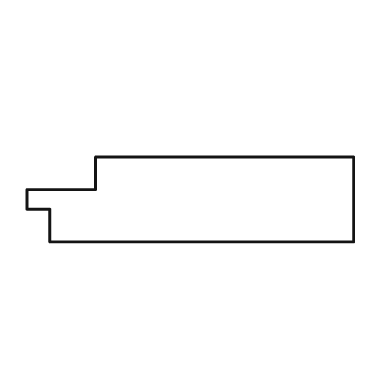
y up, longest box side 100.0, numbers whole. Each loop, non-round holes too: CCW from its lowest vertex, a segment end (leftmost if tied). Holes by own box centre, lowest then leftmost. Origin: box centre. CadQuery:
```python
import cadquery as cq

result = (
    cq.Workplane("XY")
    .moveTo(-43.0, -13.0)
    .lineTo(50.0, -13.0)
    .lineTo(50.0, 13.0)
    .lineTo(-29.0, 13.0)
    .lineTo(-29.0, 3.0)
    .lineTo(-50.0, 3.0)
    .lineTo(-50.0, -3.0)
    .lineTo(-43.0, -3.0)
    .close()
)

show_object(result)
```